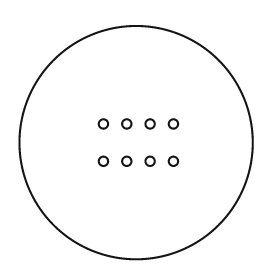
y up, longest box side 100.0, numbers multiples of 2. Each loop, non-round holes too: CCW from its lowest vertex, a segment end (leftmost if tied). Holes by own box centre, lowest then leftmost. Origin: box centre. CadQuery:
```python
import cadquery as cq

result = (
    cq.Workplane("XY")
    .moveTo(0.0, 0.0)
    .circle(50.0)
    .moveTo(-14.0, -8.0)
    .circle(2.0)
    .moveTo(-4.0, -8.0)
    .circle(2.0)
    .moveTo(6.0, -8.0)
    .circle(2.0)
    .moveTo(16.0, -8.0)
    .circle(2.0)
    .moveTo(-14.0, 8.0)
    .circle(2.0)
    .moveTo(-4.0, 8.0)
    .circle(2.0)
    .moveTo(6.0, 8.0)
    .circle(2.0)
    .moveTo(16.0, 8.0)
    .circle(2.0)
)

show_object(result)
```